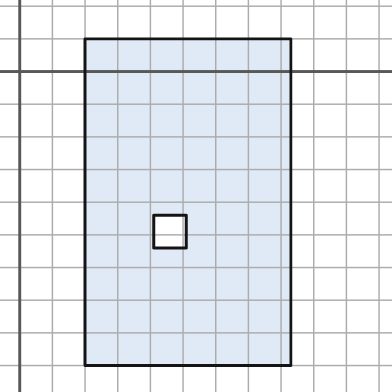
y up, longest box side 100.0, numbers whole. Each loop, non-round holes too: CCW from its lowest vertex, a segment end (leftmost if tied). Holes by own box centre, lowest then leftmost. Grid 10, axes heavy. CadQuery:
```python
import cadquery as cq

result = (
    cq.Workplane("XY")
    .moveTo(20.0, -90.0)
    .lineTo(83.0, -90.0)
    .lineTo(83.0, 10.0)
    .lineTo(20.0, 10.0)
    .close()
    .moveTo(41.0, -54.0)
    .lineTo(51.0, -54.0)
    .lineTo(51.0, -44.0)
    .lineTo(41.0, -44.0)
    .close()
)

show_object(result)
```